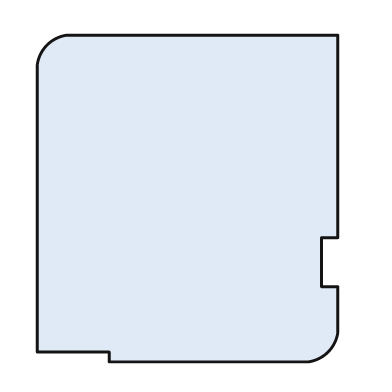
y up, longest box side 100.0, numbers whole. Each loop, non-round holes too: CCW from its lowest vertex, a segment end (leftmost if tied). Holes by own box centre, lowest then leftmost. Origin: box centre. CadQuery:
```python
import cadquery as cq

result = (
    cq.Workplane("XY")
    .moveTo(-24.0, -50.0)
    .lineTo(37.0, -50.0)
    .threePointArc((43.0, -47.0), (46.0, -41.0))
    .lineTo(46.0, -27.0)
    .lineTo(41.0, -27.0)
    .lineTo(41.0, -12.0)
    .lineTo(46.0, -12.0)
    .lineTo(46.0, 50.0)
    .lineTo(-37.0, 50.0)
    .threePointArc((-43.0, 47.0), (-46.0, 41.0))
    .lineTo(-46.0, -47.0)
    .lineTo(-24.0, -47.0)
    .close()
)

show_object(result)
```